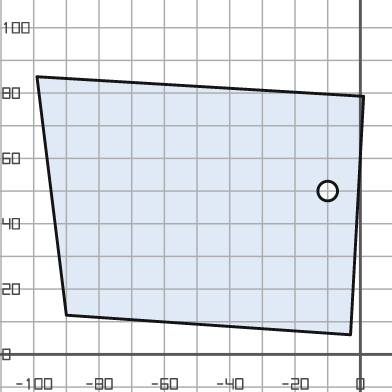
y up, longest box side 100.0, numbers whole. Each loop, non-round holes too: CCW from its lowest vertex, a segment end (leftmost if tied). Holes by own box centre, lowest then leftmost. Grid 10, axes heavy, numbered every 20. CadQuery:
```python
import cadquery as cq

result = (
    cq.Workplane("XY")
    .moveTo(-3.0, 6.0)
    .lineTo(1.0, 79.0)
    .lineTo(-99.0, 85.0)
    .lineTo(-90.0, 12.0)
    .close()
    .moveTo(-10.0, 50.0)
    .circle(3.0)
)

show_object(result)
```